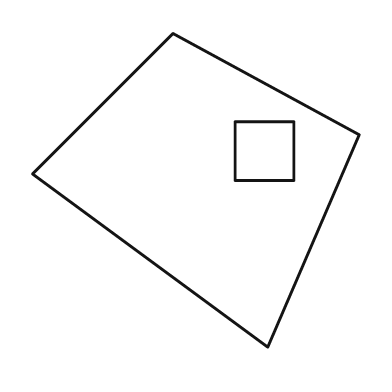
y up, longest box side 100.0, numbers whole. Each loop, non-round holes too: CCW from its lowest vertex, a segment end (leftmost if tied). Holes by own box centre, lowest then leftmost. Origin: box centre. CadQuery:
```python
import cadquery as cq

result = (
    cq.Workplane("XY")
    .moveTo(22.0, -48.0)
    .lineTo(50.0, 17.0)
    .lineTo(-7.0, 48.0)
    .lineTo(-50.0, 5.0)
    .close()
    .moveTo(12.0, 3.0)
    .lineTo(30.0, 3.0)
    .lineTo(30.0, 21.0)
    .lineTo(12.0, 21.0)
    .close()
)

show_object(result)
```